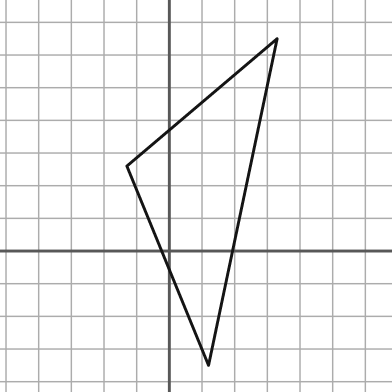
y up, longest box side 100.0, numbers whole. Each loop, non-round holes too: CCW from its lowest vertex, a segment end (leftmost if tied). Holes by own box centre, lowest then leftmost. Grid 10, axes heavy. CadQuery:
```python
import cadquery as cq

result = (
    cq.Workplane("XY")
    .moveTo(12.0, -35.0)
    .lineTo(33.0, 65.0)
    .lineTo(-13.0, 26.0)
    .close()
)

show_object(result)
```